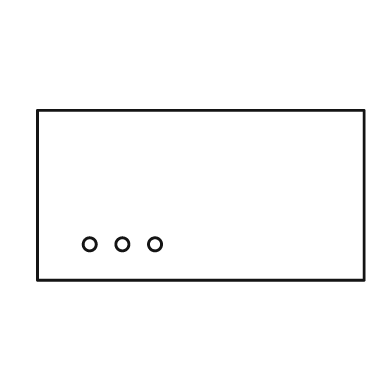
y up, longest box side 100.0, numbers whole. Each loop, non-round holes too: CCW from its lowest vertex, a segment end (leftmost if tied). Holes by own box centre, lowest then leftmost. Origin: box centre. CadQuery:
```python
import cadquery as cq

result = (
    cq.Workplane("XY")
    .moveTo(-50.0, -26.0)
    .lineTo(50.0, -26.0)
    .lineTo(50.0, 26.0)
    .lineTo(-50.0, 26.0)
    .close()
    .moveTo(-34.0, -15.0)
    .circle(2.0)
    .moveTo(-24.0, -15.0)
    .circle(2.0)
    .moveTo(-14.0, -15.0)
    .circle(2.0)
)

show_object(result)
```